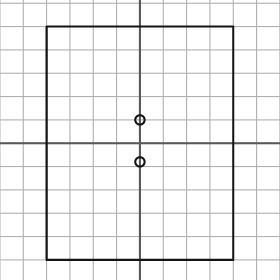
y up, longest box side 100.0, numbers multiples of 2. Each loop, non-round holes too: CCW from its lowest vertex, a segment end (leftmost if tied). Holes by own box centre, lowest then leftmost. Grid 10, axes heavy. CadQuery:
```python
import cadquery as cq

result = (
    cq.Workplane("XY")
    .moveTo(-40.0, -50.0)
    .lineTo(40.0, -50.0)
    .lineTo(40.0, 50.0)
    .lineTo(-40.0, 50.0)
    .close()
    .moveTo(0.0, -8.0)
    .circle(2.0)
    .moveTo(0.0, 10.0)
    .circle(2.0)
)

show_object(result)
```